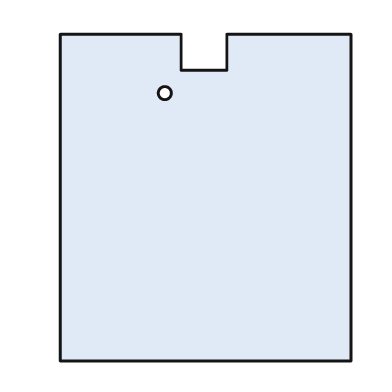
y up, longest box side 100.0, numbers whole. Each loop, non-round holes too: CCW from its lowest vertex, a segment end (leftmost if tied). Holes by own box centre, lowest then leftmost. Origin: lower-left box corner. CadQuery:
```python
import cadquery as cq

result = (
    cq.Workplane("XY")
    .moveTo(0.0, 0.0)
    .lineTo(89.0, 0.0)
    .lineTo(89.0, 100.0)
    .lineTo(51.0, 100.0)
    .lineTo(51.0, 89.0)
    .lineTo(37.0, 89.0)
    .lineTo(37.0, 100.0)
    .lineTo(0.0, 100.0)
    .close()
    .moveTo(32.0, 82.0)
    .circle(2.0)
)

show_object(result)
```